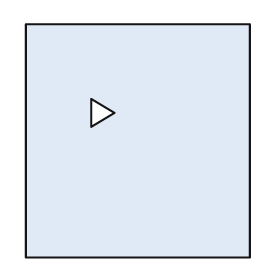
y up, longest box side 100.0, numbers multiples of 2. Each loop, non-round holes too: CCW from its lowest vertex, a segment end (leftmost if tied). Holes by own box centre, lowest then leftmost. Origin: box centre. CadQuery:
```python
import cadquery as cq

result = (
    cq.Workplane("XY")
    .moveTo(-48.0, -50.0)
    .lineTo(48.0, -50.0)
    .lineTo(48.0, 50.0)
    .lineTo(-48.0, 50.0)
    .close()
    .moveTo(-20.0, 6.0)
    .lineTo(-10.0, 12.0)
    .lineTo(-20.0, 18.0)
    .close()
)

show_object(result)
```